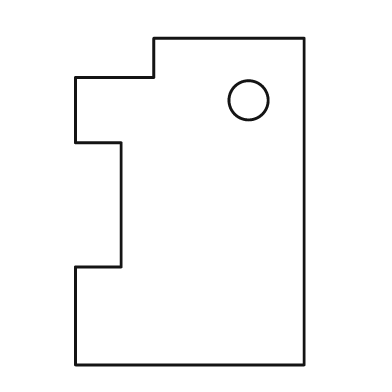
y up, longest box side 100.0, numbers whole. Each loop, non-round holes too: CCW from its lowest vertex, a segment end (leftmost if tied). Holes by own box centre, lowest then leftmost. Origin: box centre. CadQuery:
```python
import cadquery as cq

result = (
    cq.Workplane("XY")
    .moveTo(-35.0, -50.0)
    .lineTo(35.0, -50.0)
    .lineTo(35.0, 50.0)
    .lineTo(-11.0, 50.0)
    .lineTo(-11.0, 38.0)
    .lineTo(-35.0, 38.0)
    .lineTo(-35.0, 18.0)
    .lineTo(-21.0, 18.0)
    .lineTo(-21.0, -20.0)
    .lineTo(-35.0, -20.0)
    .close()
    .moveTo(18.0, 31.0)
    .circle(6.0)
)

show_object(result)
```